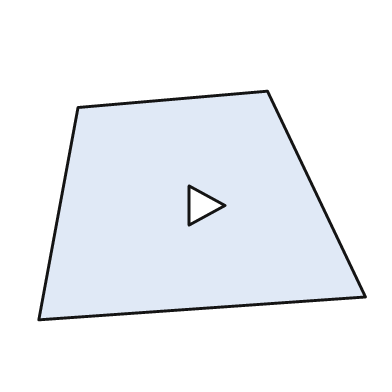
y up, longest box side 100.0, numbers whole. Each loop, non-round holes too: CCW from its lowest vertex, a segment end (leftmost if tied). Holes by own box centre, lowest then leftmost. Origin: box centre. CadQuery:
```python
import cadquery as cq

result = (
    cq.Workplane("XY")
    .moveTo(-50.0, -35.0)
    .lineTo(50.0, -28.0)
    .lineTo(20.0, 35.0)
    .lineTo(-38.0, 30.0)
    .close()
    .moveTo(-4.0, -6.0)
    .lineTo(7.0, 0.0)
    .lineTo(-4.0, 6.0)
    .close()
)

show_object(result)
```